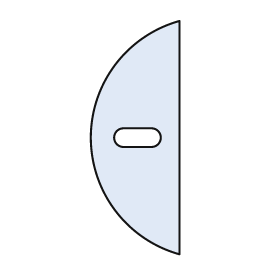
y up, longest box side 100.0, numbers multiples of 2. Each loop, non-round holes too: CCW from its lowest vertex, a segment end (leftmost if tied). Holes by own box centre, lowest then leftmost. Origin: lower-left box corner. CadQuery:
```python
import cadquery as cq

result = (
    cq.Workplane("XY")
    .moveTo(38.0, 0.0)
    .lineTo(38.0, 100.0)
    .threePointArc((0.0, 50.0), (38.0, 0.0))
    .close()
    .moveTo(14.0, 46.0)
    .lineTo(26.0, 46.0)
    .threePointArc((30.0, 50.0), (26.0, 54.0))
    .lineTo(14.0, 54.0)
    .threePointArc((10.0, 50.0), (14.0, 46.0))
    .close()
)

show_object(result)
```